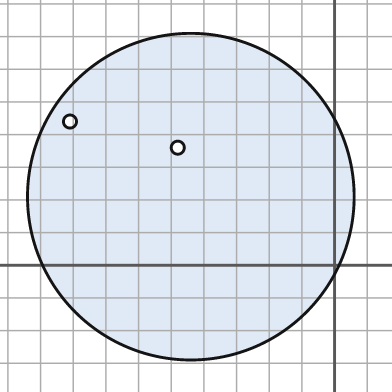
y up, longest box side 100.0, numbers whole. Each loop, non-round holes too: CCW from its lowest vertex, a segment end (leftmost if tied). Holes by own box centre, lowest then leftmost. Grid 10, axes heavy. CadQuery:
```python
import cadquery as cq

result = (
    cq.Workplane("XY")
    .moveTo(-44.0, 21.0)
    .circle(50.0)
    .moveTo(-48.0, 36.0)
    .circle(2.0)
    .moveTo(-81.0, 44.0)
    .circle(2.0)
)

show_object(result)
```